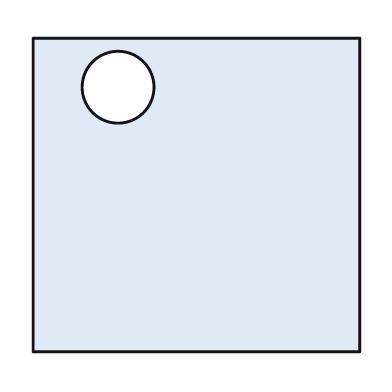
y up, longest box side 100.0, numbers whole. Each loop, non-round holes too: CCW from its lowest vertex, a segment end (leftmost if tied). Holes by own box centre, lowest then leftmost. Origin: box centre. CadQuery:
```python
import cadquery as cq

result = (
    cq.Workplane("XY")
    .moveTo(-50.0, -48.0)
    .lineTo(50.0, -48.0)
    .lineTo(50.0, 48.0)
    .lineTo(-50.0, 48.0)
    .close()
    .moveTo(-24.0, 33.0)
    .circle(11.0)
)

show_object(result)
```